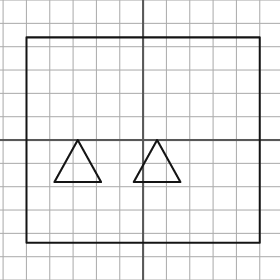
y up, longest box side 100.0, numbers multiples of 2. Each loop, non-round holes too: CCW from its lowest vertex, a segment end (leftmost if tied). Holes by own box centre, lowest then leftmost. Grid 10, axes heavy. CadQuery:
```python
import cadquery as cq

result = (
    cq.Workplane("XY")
    .moveTo(-50.0, -44.0)
    .lineTo(50.0, -44.0)
    .lineTo(50.0, 44.0)
    .lineTo(-50.0, 44.0)
    .close()
    .moveTo(-38.0, -18.0)
    .lineTo(-18.0, -18.0)
    .lineTo(-28.0, 0.0)
    .close()
    .moveTo(-4.0, -18.0)
    .lineTo(16.0, -18.0)
    .lineTo(6.0, 0.0)
    .close()
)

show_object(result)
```